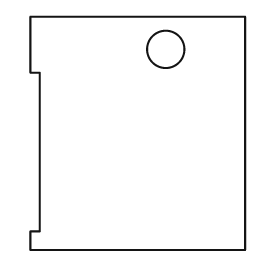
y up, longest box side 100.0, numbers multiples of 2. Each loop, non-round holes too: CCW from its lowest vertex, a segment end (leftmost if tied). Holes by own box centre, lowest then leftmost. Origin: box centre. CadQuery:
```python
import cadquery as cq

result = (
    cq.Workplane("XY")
    .moveTo(-46.0, -50.0)
    .lineTo(46.0, -50.0)
    .lineTo(46.0, 50.0)
    .lineTo(-46.0, 50.0)
    .lineTo(-46.0, 26.0)
    .lineTo(-42.0, 26.0)
    .lineTo(-42.0, -42.0)
    .lineTo(-46.0, -42.0)
    .close()
    .moveTo(12.0, 36.0)
    .circle(8.0)
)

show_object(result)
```